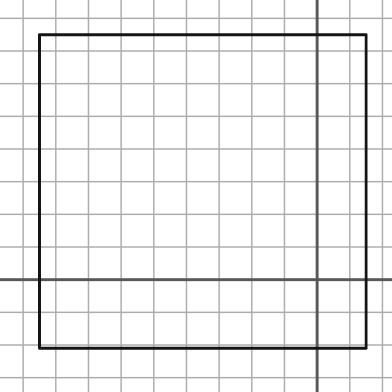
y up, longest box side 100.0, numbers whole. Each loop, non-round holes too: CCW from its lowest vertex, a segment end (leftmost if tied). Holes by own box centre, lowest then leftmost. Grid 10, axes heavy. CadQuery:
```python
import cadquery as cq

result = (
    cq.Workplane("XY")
    .moveTo(-85.0, -21.0)
    .lineTo(15.0, -21.0)
    .lineTo(15.0, 75.0)
    .lineTo(-85.0, 75.0)
    .close()
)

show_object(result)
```